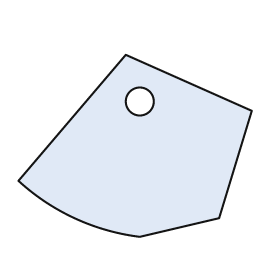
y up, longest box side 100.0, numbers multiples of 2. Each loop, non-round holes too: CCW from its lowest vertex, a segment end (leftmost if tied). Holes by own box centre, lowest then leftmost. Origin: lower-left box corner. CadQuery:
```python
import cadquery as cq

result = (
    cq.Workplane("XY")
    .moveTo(52.0, 0.0)
    .lineTo(86.0, 8.0)
    .lineTo(100.0, 54.0)
    .lineTo(46.0, 78.0)
    .lineTo(0.0, 24.0)
    .threePointArc((24.0, 8.0), (52.0, 0.0))
    .close()
    .moveTo(52.0, 58.0)
    .circle(6.0)
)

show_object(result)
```